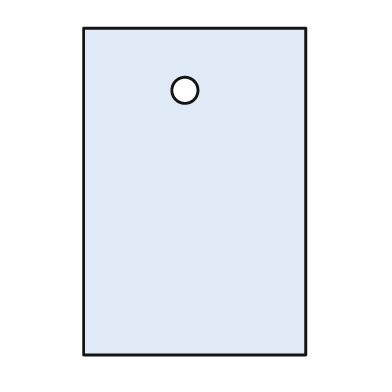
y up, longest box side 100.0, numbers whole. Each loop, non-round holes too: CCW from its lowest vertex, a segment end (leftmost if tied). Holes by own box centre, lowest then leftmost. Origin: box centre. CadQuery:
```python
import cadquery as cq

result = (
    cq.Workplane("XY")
    .moveTo(-34.0, -50.0)
    .lineTo(34.0, -50.0)
    .lineTo(34.0, 50.0)
    .lineTo(-34.0, 50.0)
    .close()
    .moveTo(-3.0, 31.0)
    .circle(4.0)
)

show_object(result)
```